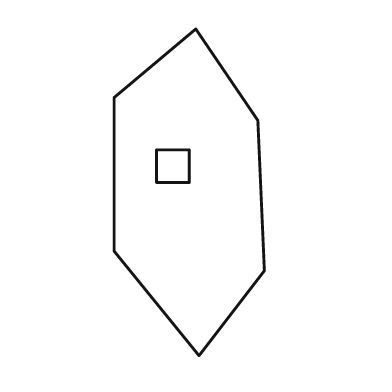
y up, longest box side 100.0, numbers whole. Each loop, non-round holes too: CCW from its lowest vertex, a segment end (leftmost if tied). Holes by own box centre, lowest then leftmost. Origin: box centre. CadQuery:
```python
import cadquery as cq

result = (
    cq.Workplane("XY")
    .moveTo(3.0, -50.0)
    .lineTo(23.0, -24.0)
    .lineTo(21.0, 22.0)
    .lineTo(2.0, 50.0)
    .lineTo(-23.0, 29.0)
    .lineTo(-23.0, -18.0)
    .close()
    .moveTo(-10.0, 3.0)
    .lineTo(0.0, 3.0)
    .lineTo(0.0, 13.0)
    .lineTo(-10.0, 13.0)
    .close()
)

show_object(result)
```